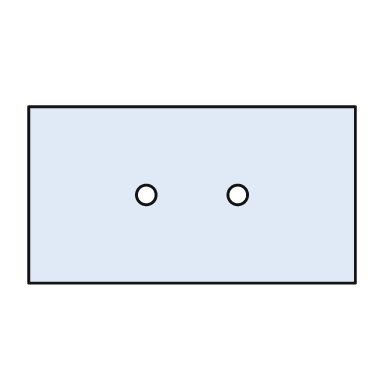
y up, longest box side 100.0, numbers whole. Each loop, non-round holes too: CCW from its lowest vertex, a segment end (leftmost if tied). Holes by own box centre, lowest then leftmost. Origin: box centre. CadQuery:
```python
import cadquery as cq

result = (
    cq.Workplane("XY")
    .moveTo(-50.0, -27.0)
    .lineTo(50.0, -27.0)
    .lineTo(50.0, 27.0)
    .lineTo(-50.0, 27.0)
    .close()
    .moveTo(-14.0, 0.0)
    .circle(3.0)
    .moveTo(14.0, 0.0)
    .circle(3.0)
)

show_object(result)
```